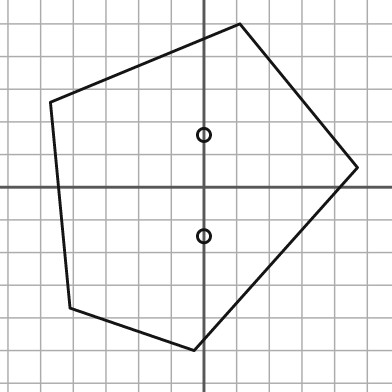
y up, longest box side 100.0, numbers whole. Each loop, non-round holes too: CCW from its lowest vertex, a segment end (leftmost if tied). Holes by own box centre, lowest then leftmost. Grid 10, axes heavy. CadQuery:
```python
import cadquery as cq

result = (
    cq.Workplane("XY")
    .moveTo(-3.0, -50.0)
    .lineTo(47.0, 6.0)
    .lineTo(11.0, 50.0)
    .lineTo(-47.0, 26.0)
    .lineTo(-41.0, -37.0)
    .close()
    .moveTo(0.0, -15.0)
    .circle(2.0)
    .moveTo(0.0, 16.0)
    .circle(2.0)
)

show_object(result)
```